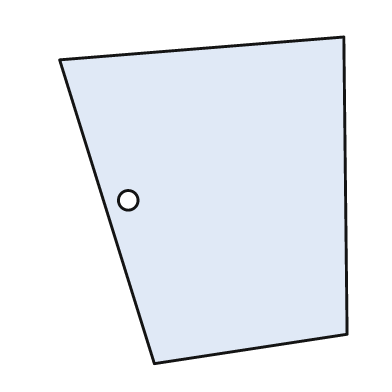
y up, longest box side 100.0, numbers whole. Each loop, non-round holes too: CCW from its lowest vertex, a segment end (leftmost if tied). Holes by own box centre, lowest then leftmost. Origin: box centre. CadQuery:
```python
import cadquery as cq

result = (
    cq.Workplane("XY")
    .moveTo(-15.0, -50.0)
    .lineTo(44.0, -41.0)
    .lineTo(43.0, 50.0)
    .lineTo(-44.0, 43.0)
    .close()
    .moveTo(-23.0, 0.0)
    .circle(3.0)
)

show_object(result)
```